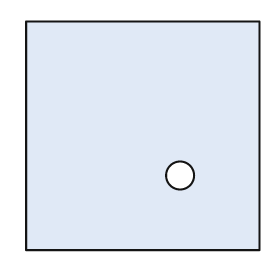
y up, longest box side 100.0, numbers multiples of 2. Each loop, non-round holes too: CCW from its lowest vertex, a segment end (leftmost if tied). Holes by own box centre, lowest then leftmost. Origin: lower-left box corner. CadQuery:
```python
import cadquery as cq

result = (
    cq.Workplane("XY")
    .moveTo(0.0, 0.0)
    .lineTo(100.0, 0.0)
    .lineTo(100.0, 98.0)
    .lineTo(0.0, 98.0)
    .close()
    .moveTo(66.0, 32.0)
    .circle(6.0)
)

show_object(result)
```